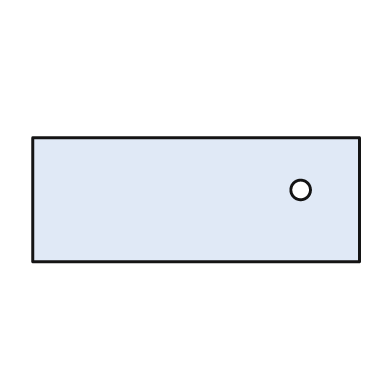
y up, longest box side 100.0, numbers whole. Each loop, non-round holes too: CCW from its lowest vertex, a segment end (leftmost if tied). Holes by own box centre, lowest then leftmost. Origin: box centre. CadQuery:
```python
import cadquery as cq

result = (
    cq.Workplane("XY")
    .moveTo(-50.0, -19.0)
    .lineTo(50.0, -19.0)
    .lineTo(50.0, 19.0)
    .lineTo(-50.0, 19.0)
    .close()
    .moveTo(32.0, 3.0)
    .circle(3.0)
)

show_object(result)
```